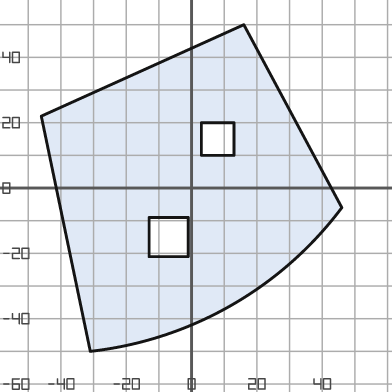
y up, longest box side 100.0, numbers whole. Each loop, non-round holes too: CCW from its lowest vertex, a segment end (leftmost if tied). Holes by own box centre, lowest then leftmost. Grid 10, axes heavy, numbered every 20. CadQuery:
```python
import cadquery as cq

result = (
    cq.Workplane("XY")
    .moveTo(-31.0, -50.0)
    .threePointArc((12.0, -36.0), (46.0, -6.0))
    .lineTo(16.0, 50.0)
    .lineTo(-46.0, 22.0)
    .close()
    .moveTo(-13.0, -21.0)
    .lineTo(-1.0, -21.0)
    .lineTo(-1.0, -9.0)
    .lineTo(-13.0, -9.0)
    .close()
    .moveTo(3.0, 10.0)
    .lineTo(13.0, 10.0)
    .lineTo(13.0, 20.0)
    .lineTo(3.0, 20.0)
    .close()
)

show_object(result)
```